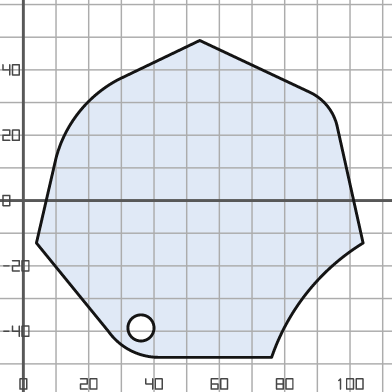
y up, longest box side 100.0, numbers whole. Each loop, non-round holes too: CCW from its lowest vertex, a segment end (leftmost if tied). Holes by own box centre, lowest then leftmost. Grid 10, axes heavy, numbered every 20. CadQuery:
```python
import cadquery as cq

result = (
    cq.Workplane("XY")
    .moveTo(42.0, -48.0)
    .lineTo(76.0, -48.0)
    .threePointArc((87.0, -28.0), (104.0, -13.0))
    .lineTo(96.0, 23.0)
    .threePointArc((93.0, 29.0), (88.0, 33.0))
    .lineTo(54.0, 49.0)
    .lineTo(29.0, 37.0)
    .threePointArc((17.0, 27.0), (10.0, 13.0))
    .lineTo(4.0, -13.0)
    .lineTo(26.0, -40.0)
    .threePointArc((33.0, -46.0), (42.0, -48.0))
    .close()
    .moveTo(36.0, -39.0)
    .circle(4.0)
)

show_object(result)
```